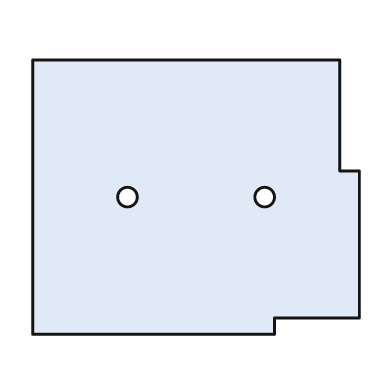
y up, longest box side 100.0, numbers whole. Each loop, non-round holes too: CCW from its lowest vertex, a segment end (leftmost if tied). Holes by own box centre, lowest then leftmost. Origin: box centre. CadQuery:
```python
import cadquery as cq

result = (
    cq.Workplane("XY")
    .moveTo(-50.0, -42.0)
    .lineTo(24.0, -42.0)
    .lineTo(24.0, -37.0)
    .lineTo(50.0, -37.0)
    .lineTo(50.0, 8.0)
    .lineTo(44.0, 8.0)
    .lineTo(44.0, 42.0)
    .lineTo(-50.0, 42.0)
    .close()
    .moveTo(-21.0, 0.0)
    .circle(3.0)
    .moveTo(21.0, 0.0)
    .circle(3.0)
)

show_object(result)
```